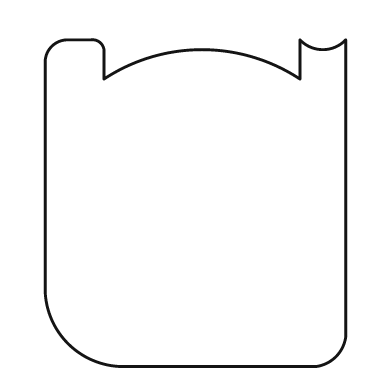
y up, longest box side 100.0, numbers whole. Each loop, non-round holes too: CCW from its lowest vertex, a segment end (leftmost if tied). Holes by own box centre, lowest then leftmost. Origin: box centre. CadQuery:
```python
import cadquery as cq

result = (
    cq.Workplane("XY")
    .moveTo(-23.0, -50.0)
    .lineTo(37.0, -50.0)
    .threePointArc((43.0, -47.0), (46.0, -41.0))
    .lineTo(46.0, 50.0)
    .threePointArc((39.0, 47.0), (32.0, 50.0))
    .lineTo(32.0, 38.0)
    .threePointArc((2.0, 47.0), (-28.0, 38.0))
    .lineTo(-28.0, 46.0)
    .threePointArc((-29.0, 49.0), (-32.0, 50.0))
    .lineTo(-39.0, 50.0)
    .threePointArc((-44.0, 48.0), (-46.0, 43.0))
    .lineTo(-46.0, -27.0)
    .threePointArc((-39.0, -43.0), (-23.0, -50.0))
    .close()
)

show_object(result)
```